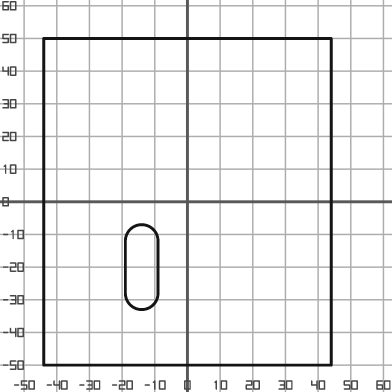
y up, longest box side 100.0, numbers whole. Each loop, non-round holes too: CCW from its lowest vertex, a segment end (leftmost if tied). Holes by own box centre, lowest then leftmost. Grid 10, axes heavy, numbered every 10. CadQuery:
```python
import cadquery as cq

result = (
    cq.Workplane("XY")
    .moveTo(-44.0, -50.0)
    .lineTo(44.0, -50.0)
    .lineTo(44.0, 50.0)
    .lineTo(-44.0, 50.0)
    .close()
    .moveTo(-19.0, -28.0)
    .threePointArc((-14.0, -33.0), (-9.0, -28.0))
    .lineTo(-9.0, -12.0)
    .threePointArc((-14.0, -7.0), (-19.0, -12.0))
    .close()
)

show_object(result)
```